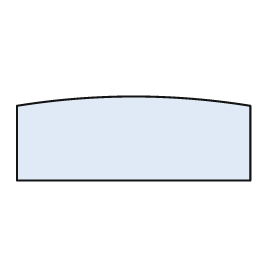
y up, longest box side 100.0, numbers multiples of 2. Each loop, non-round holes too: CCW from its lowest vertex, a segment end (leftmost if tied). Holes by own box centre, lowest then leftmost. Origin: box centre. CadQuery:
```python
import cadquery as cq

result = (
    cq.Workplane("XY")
    .moveTo(-50.0, -18.0)
    .lineTo(50.0, -18.0)
    .lineTo(50.0, 14.0)
    .threePointArc((0.0, 18.0), (-50.0, 14.0))
    .close()
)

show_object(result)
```